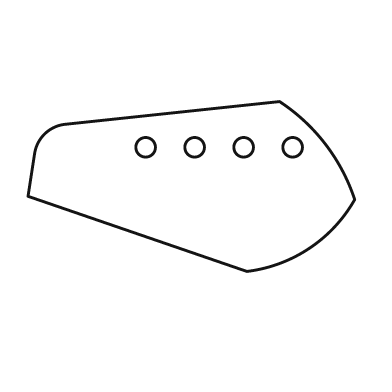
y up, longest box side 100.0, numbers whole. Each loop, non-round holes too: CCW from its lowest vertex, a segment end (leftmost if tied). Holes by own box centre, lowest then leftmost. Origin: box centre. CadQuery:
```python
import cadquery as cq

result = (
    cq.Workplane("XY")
    .moveTo(17.0, -26.0)
    .threePointArc((36.0, -19.0), (50.0, -4.0))
    .threePointArc((41.0, 13.0), (27.0, 26.0))
    .lineTo(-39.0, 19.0)
    .threePointArc((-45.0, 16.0), (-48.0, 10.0))
    .lineTo(-50.0, -3.0)
    .close()
    .moveTo(-14.0, 12.0)
    .circle(3.0)
    .moveTo(1.0, 12.0)
    .circle(3.0)
    .moveTo(16.0, 12.0)
    .circle(3.0)
    .moveTo(31.0, 12.0)
    .circle(3.0)
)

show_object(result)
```